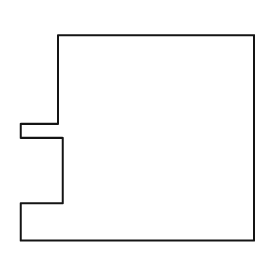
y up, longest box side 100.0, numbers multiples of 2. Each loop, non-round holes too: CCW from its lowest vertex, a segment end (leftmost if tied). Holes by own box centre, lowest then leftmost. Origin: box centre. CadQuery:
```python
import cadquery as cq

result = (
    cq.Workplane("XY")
    .moveTo(-50.0, -44.0)
    .lineTo(50.0, -44.0)
    .lineTo(50.0, 44.0)
    .lineTo(-34.0, 44.0)
    .lineTo(-34.0, 6.0)
    .lineTo(-50.0, 6.0)
    .lineTo(-50.0, 0.0)
    .lineTo(-32.0, 0.0)
    .lineTo(-32.0, -28.0)
    .lineTo(-50.0, -28.0)
    .close()
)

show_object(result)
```